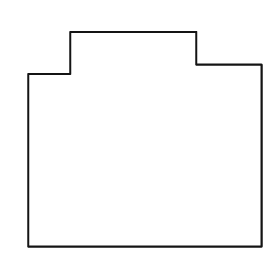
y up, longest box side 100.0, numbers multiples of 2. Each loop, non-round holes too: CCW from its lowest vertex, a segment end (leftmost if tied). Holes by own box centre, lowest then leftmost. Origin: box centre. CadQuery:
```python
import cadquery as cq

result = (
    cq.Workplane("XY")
    .moveTo(-50.0, -46.0)
    .lineTo(50.0, -46.0)
    .lineTo(50.0, 32.0)
    .lineTo(22.0, 32.0)
    .lineTo(22.0, 46.0)
    .lineTo(-32.0, 46.0)
    .lineTo(-32.0, 28.0)
    .lineTo(-50.0, 28.0)
    .close()
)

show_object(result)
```